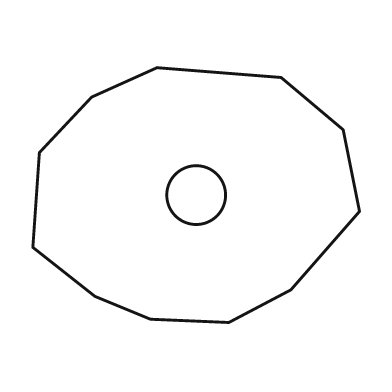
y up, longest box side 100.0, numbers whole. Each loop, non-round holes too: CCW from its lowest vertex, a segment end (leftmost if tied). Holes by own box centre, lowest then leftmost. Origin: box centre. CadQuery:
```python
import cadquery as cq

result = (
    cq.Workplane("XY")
    .moveTo(10.0, -39.0)
    .lineTo(29.0, -29.0)
    .lineTo(50.0, -5.0)
    .lineTo(45.0, 20.0)
    .lineTo(26.0, 36.0)
    .lineTo(-12.0, 39.0)
    .lineTo(-32.0, 30.0)
    .lineTo(-48.0, 13.0)
    .lineTo(-50.0, -16.0)
    .lineTo(-31.0, -31.0)
    .lineTo(-14.0, -38.0)
    .close()
    .moveTo(0.0, 0.0)
    .circle(9.0)
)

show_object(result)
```